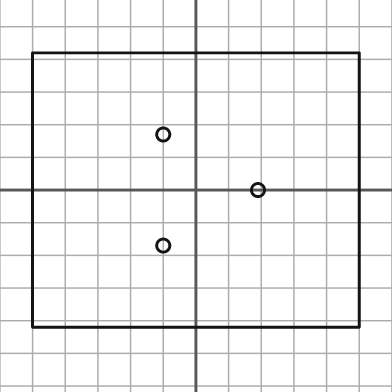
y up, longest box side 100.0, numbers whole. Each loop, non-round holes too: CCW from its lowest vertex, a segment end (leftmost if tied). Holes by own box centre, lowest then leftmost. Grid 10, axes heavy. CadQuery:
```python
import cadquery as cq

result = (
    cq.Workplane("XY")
    .moveTo(-50.0, -42.0)
    .lineTo(50.0, -42.0)
    .lineTo(50.0, 42.0)
    .lineTo(-50.0, 42.0)
    .close()
    .moveTo(-10.0, -17.0)
    .circle(2.0)
    .moveTo(19.0, 0.0)
    .circle(2.0)
    .moveTo(-10.0, 17.0)
    .circle(2.0)
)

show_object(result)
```